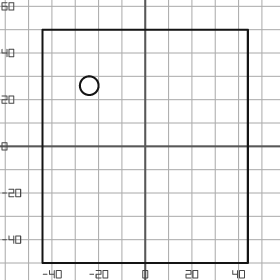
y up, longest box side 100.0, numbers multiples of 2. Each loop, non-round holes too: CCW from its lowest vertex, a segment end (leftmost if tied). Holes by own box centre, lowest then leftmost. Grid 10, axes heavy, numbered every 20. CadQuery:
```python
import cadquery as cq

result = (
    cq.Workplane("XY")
    .moveTo(-44.0, -50.0)
    .lineTo(44.0, -50.0)
    .lineTo(44.0, 50.0)
    .lineTo(-44.0, 50.0)
    .close()
    .moveTo(-24.0, 26.0)
    .circle(4.0)
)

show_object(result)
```